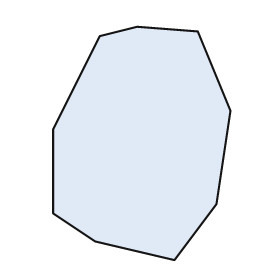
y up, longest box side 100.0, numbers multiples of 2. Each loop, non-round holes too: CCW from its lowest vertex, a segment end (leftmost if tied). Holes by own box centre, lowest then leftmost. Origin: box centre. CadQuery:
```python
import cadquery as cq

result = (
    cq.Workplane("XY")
    .moveTo(14.0, -50.0)
    .lineTo(32.0, -26.0)
    .lineTo(38.0, 14.0)
    .lineTo(24.0, 48.0)
    .lineTo(-2.0, 50.0)
    .lineTo(-18.0, 46.0)
    .lineTo(-38.0, 6.0)
    .lineTo(-38.0, -30.0)
    .lineTo(-20.0, -42.0)
    .close()
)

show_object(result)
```